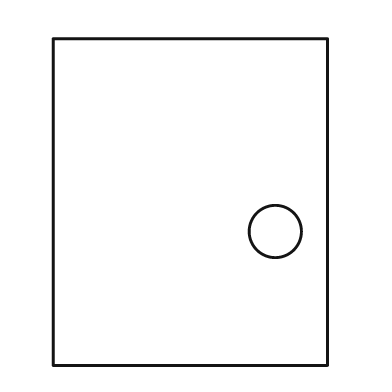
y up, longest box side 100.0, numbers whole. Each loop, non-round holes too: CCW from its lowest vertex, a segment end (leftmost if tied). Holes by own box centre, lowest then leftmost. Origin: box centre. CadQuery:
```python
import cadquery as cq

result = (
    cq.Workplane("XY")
    .moveTo(-42.0, -50.0)
    .lineTo(42.0, -50.0)
    .lineTo(42.0, 50.0)
    .lineTo(-42.0, 50.0)
    .close()
    .moveTo(26.0, -9.0)
    .circle(8.0)
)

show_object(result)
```